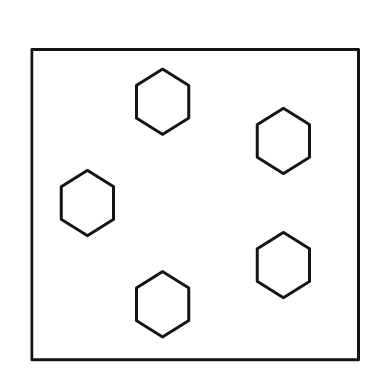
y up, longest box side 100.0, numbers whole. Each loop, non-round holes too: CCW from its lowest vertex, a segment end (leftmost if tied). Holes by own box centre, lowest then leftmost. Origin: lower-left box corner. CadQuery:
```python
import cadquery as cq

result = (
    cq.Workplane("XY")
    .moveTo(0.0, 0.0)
    .lineTo(100.0, 0.0)
    .lineTo(100.0, 95.0)
    .lineTo(0.0, 95.0)
    .close()
    .moveTo(40.0, 7.0)
    .lineTo(48.0, 12.0)
    .lineTo(48.0, 22.0)
    .lineTo(40.0, 27.0)
    .lineTo(32.0, 22.0)
    .lineTo(32.0, 12.0)
    .close()
    .moveTo(77.0, 19.0)
    .lineTo(85.0, 24.0)
    .lineTo(85.0, 34.0)
    .lineTo(77.0, 39.0)
    .lineTo(69.0, 34.0)
    .lineTo(69.0, 24.0)
    .close()
    .moveTo(17.0, 38.0)
    .lineTo(25.0, 43.0)
    .lineTo(25.0, 53.0)
    .lineTo(17.0, 58.0)
    .lineTo(9.0, 53.0)
    .lineTo(9.0, 43.0)
    .close()
    .moveTo(77.0, 57.0)
    .lineTo(85.0, 62.0)
    .lineTo(85.0, 72.0)
    .lineTo(77.0, 77.0)
    .lineTo(69.0, 72.0)
    .lineTo(69.0, 62.0)
    .close()
    .moveTo(40.0, 69.0)
    .lineTo(48.0, 74.0)
    .lineTo(48.0, 84.0)
    .lineTo(40.0, 89.0)
    .lineTo(32.0, 84.0)
    .lineTo(32.0, 74.0)
    .close()
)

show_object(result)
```